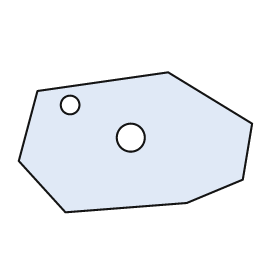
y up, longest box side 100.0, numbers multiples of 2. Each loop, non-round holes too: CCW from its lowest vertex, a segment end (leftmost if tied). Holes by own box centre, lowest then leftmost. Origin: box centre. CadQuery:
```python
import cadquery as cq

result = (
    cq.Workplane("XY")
    .moveTo(-30.0, -30.0)
    .lineTo(22.0, -26.0)
    .lineTo(46.0, -16.0)
    .lineTo(50.0, 8.0)
    .lineTo(14.0, 30.0)
    .lineTo(-42.0, 22.0)
    .lineTo(-50.0, -8.0)
    .close()
    .moveTo(-2.0, 2.0)
    .circle(6.0)
    .moveTo(-28.0, 16.0)
    .circle(4.0)
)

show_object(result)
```